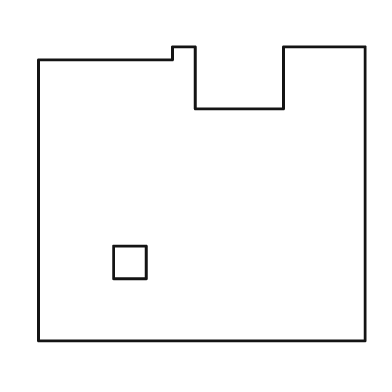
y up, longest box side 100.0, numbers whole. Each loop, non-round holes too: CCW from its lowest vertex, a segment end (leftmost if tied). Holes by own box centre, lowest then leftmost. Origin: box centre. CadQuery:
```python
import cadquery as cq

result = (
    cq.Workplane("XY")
    .moveTo(-50.0, -45.0)
    .lineTo(50.0, -45.0)
    .lineTo(50.0, 45.0)
    .lineTo(25.0, 45.0)
    .lineTo(25.0, 26.0)
    .lineTo(-2.0, 26.0)
    .lineTo(-2.0, 45.0)
    .lineTo(-9.0, 45.0)
    .lineTo(-9.0, 41.0)
    .lineTo(-50.0, 41.0)
    .close()
    .moveTo(-27.0, -26.0)
    .lineTo(-17.0, -26.0)
    .lineTo(-17.0, -16.0)
    .lineTo(-27.0, -16.0)
    .close()
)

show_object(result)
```